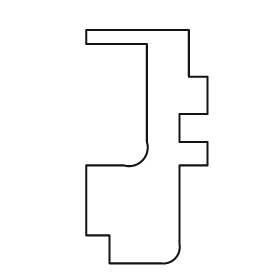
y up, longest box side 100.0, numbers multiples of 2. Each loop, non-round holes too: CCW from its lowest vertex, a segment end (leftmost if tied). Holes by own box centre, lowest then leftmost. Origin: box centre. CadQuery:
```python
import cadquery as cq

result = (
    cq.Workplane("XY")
    .moveTo(-16.0, -50.0)
    .lineTo(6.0, -50.0)
    .threePointArc((12.0, -48.0), (14.0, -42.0))
    .lineTo(14.0, -8.0)
    .lineTo(26.0, -8.0)
    .lineTo(26.0, 2.0)
    .lineTo(14.0, 2.0)
    .lineTo(14.0, 14.0)
    .lineTo(26.0, 14.0)
    .lineTo(26.0, 30.0)
    .lineTo(18.0, 30.0)
    .lineTo(18.0, 50.0)
    .lineTo(-26.0, 50.0)
    .lineTo(-26.0, 44.0)
    .lineTo(0.0, 44.0)
    .lineTo(0.0, 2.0)
    .threePointArc((-2.0, -6.0), (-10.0, -8.0))
    .lineTo(-26.0, -8.0)
    .lineTo(-26.0, -38.0)
    .lineTo(-16.0, -38.0)
    .close()
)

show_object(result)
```